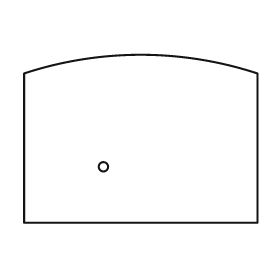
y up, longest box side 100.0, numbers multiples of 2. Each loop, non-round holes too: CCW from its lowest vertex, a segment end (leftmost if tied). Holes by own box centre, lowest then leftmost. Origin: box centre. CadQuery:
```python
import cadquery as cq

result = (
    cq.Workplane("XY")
    .moveTo(-50.0, -36.0)
    .lineTo(50.0, -36.0)
    .lineTo(50.0, 28.0)
    .threePointArc((0.0, 36.0), (-50.0, 28.0))
    .close()
    .moveTo(-16.0, -12.0)
    .circle(2.0)
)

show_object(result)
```